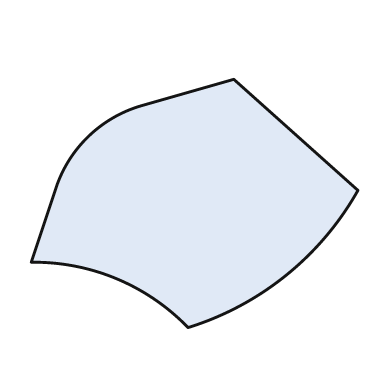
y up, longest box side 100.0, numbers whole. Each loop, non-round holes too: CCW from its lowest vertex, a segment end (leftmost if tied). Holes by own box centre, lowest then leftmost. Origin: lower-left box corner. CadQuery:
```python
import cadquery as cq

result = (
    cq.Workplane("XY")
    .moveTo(48.0, 0.0)
    .threePointArc((78.0, 16.0), (100.0, 42.0))
    .lineTo(62.0, 76.0)
    .lineTo(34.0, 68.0)
    .threePointArc((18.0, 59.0), (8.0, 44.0))
    .lineTo(0.0, 20.0)
    .threePointArc((26.0, 15.0), (48.0, 0.0))
    .close()
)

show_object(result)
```